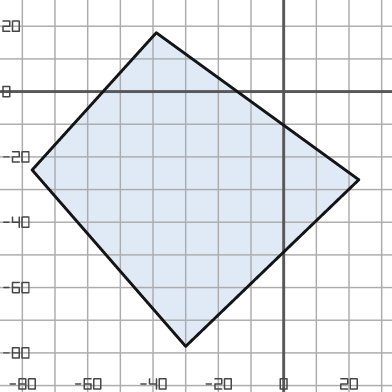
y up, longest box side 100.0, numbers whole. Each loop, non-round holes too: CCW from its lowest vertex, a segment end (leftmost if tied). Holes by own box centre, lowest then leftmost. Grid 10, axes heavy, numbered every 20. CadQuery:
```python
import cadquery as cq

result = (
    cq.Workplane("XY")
    .moveTo(-30.0, -78.0)
    .lineTo(23.0, -27.0)
    .lineTo(-39.0, 18.0)
    .lineTo(-77.0, -24.0)
    .close()
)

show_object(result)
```